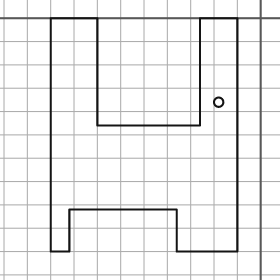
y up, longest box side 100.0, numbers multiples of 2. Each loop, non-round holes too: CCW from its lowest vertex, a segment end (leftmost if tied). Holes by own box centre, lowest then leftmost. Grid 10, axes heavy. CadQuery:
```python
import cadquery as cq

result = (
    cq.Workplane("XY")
    .moveTo(-90.0, -100.0)
    .lineTo(-82.0, -100.0)
    .lineTo(-82.0, -82.0)
    .lineTo(-36.0, -82.0)
    .lineTo(-36.0, -100.0)
    .lineTo(-10.0, -100.0)
    .lineTo(-10.0, 0.0)
    .lineTo(-26.0, 0.0)
    .lineTo(-26.0, -46.0)
    .lineTo(-70.0, -46.0)
    .lineTo(-70.0, 0.0)
    .lineTo(-90.0, 0.0)
    .close()
    .moveTo(-18.0, -36.0)
    .circle(2.0)
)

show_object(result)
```